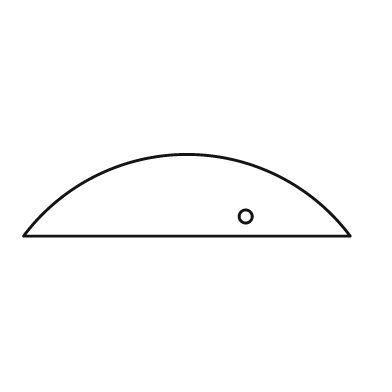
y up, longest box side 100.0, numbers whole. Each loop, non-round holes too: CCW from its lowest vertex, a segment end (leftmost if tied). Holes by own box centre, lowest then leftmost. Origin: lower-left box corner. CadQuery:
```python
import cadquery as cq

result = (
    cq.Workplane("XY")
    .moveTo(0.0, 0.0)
    .lineTo(100.0, 0.0)
    .threePointArc((50.0, 25.0), (0.0, 0.0))
    .close()
    .moveTo(68.0, 6.0)
    .circle(2.0)
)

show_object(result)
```